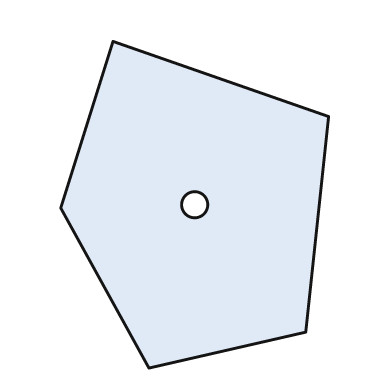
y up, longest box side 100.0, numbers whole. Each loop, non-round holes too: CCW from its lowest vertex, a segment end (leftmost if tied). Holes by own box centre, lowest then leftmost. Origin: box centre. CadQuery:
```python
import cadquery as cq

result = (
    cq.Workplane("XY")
    .moveTo(-14.0, -50.0)
    .lineTo(34.0, -39.0)
    .lineTo(41.0, 27.0)
    .lineTo(-25.0, 50.0)
    .lineTo(-41.0, -1.0)
    .close()
    .moveTo(0.0, 0.0)
    .circle(4.0)
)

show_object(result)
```